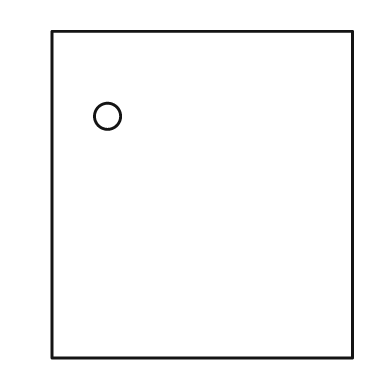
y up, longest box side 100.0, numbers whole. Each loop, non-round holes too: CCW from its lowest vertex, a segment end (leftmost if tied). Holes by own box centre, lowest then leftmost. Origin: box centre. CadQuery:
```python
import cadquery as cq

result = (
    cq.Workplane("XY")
    .moveTo(-46.0, -50.0)
    .lineTo(46.0, -50.0)
    .lineTo(46.0, 50.0)
    .lineTo(-46.0, 50.0)
    .close()
    .moveTo(-29.0, 24.0)
    .circle(4.0)
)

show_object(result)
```